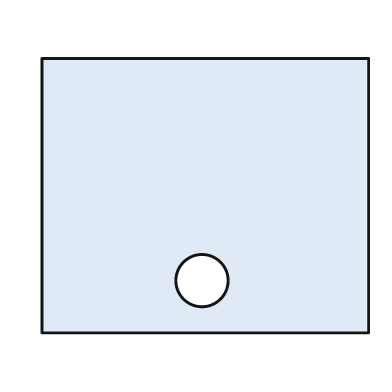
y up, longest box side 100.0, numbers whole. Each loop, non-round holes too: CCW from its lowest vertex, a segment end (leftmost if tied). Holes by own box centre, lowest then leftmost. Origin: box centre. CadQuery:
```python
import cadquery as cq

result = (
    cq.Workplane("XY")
    .moveTo(-50.0, -42.0)
    .lineTo(50.0, -42.0)
    .lineTo(50.0, 42.0)
    .lineTo(-50.0, 42.0)
    .close()
    .moveTo(-1.0, -26.0)
    .circle(8.0)
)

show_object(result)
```